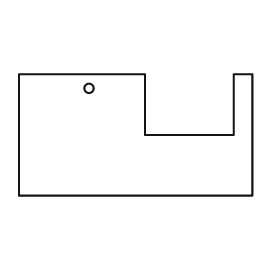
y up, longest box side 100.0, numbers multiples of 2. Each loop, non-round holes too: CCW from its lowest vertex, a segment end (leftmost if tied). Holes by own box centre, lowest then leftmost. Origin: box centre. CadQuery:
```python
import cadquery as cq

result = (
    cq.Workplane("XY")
    .moveTo(-50.0, -26.0)
    .lineTo(50.0, -26.0)
    .lineTo(50.0, 26.0)
    .lineTo(42.0, 26.0)
    .lineTo(42.0, 0.0)
    .lineTo(4.0, 0.0)
    .lineTo(4.0, 26.0)
    .lineTo(-50.0, 26.0)
    .close()
    .moveTo(-20.0, 20.0)
    .circle(2.0)
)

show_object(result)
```